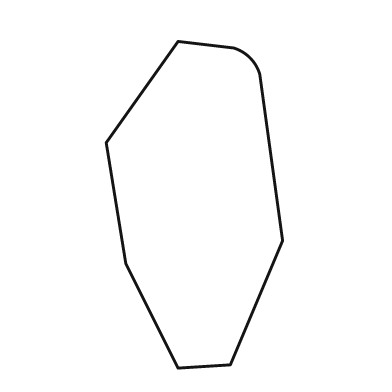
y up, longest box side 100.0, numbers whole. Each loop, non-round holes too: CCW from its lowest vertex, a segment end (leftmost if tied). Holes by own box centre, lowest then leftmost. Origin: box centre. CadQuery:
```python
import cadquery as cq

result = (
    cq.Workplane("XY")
    .moveTo(-5.0, -50.0)
    .lineTo(11.0, -49.0)
    .lineTo(27.0, -11.0)
    .lineTo(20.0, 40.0)
    .threePointArc((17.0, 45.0), (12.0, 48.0))
    .lineTo(-5.0, 50.0)
    .lineTo(-27.0, 19.0)
    .lineTo(-21.0, -18.0)
    .close()
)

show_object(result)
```